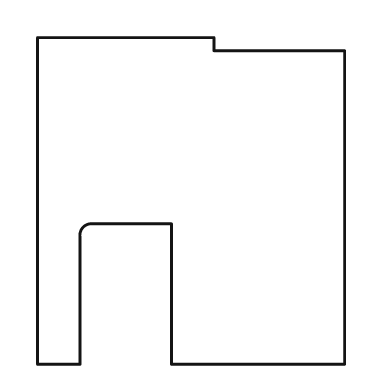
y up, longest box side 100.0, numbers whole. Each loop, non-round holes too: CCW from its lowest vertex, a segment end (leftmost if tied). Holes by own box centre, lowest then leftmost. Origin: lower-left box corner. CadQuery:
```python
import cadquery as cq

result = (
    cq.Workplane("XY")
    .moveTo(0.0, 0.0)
    .lineTo(13.0, 0.0)
    .lineTo(13.0, 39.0)
    .threePointArc((14.0, 42.0), (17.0, 43.0))
    .lineTo(41.0, 43.0)
    .lineTo(41.0, 0.0)
    .lineTo(94.0, 0.0)
    .lineTo(94.0, 96.0)
    .lineTo(54.0, 96.0)
    .lineTo(54.0, 100.0)
    .lineTo(0.0, 100.0)
    .close()
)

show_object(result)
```